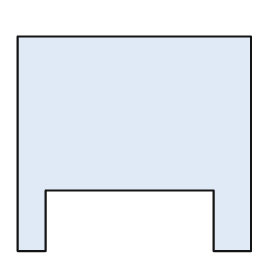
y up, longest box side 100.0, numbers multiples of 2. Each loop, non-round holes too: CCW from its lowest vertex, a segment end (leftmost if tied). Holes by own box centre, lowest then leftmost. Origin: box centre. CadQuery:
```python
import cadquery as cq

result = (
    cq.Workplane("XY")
    .moveTo(-50.0, -46.0)
    .lineTo(-38.0, -46.0)
    .lineTo(-38.0, -20.0)
    .lineTo(34.0, -20.0)
    .lineTo(34.0, -46.0)
    .lineTo(50.0, -46.0)
    .lineTo(50.0, 46.0)
    .lineTo(-50.0, 46.0)
    .close()
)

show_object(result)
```